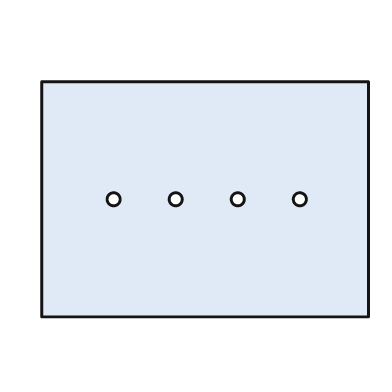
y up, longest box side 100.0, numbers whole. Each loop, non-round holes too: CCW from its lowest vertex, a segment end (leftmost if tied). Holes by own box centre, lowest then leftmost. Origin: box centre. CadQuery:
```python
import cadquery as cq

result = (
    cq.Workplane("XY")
    .moveTo(-50.0, -36.0)
    .lineTo(50.0, -36.0)
    .lineTo(50.0, 36.0)
    .lineTo(-50.0, 36.0)
    .close()
    .moveTo(-28.0, 0.0)
    .circle(2.0)
    .moveTo(-9.0, 0.0)
    .circle(2.0)
    .moveTo(10.0, 0.0)
    .circle(2.0)
    .moveTo(29.0, 0.0)
    .circle(2.0)
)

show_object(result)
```